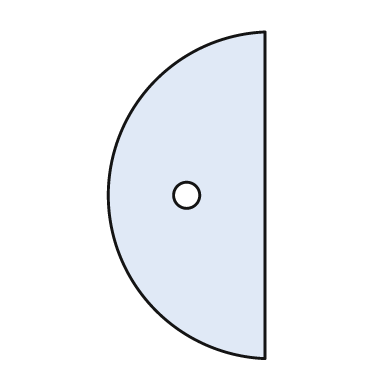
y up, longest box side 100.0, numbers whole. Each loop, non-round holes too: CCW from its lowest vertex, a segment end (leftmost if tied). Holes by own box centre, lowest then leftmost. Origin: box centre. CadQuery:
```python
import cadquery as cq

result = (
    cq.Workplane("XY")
    .moveTo(24.0, -50.0)
    .lineTo(24.0, 50.0)
    .threePointArc((-24.0, 0.0), (24.0, -50.0))
    .close()
    .moveTo(0.0, 0.0)
    .circle(4.0)
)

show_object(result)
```